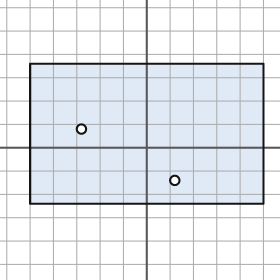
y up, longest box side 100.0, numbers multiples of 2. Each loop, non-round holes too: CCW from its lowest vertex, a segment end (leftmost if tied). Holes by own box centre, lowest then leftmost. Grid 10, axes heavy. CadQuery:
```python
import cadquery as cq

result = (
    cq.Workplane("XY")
    .moveTo(-50.0, -24.0)
    .lineTo(50.0, -24.0)
    .lineTo(50.0, 36.0)
    .lineTo(-50.0, 36.0)
    .close()
    .moveTo(12.0, -14.0)
    .circle(2.0)
    .moveTo(-28.0, 8.0)
    .circle(2.0)
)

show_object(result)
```